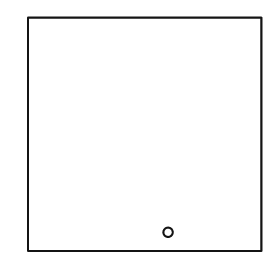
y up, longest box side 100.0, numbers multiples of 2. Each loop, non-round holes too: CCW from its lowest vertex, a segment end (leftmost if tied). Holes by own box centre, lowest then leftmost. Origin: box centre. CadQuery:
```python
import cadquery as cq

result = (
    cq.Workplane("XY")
    .moveTo(-50.0, -50.0)
    .lineTo(50.0, -50.0)
    .lineTo(50.0, 50.0)
    .lineTo(-50.0, 50.0)
    .close()
    .moveTo(10.0, -42.0)
    .circle(2.0)
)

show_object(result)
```